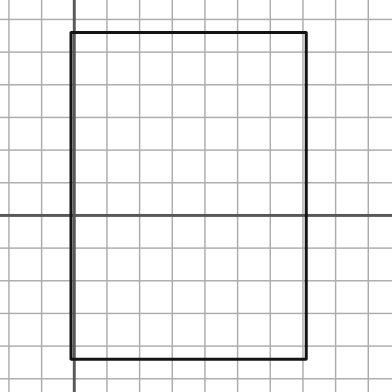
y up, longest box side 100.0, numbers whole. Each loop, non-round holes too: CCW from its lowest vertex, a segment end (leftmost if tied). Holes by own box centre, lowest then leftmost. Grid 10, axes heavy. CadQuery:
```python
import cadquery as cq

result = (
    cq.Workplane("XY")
    .moveTo(-1.0, -44.0)
    .lineTo(71.0, -44.0)
    .lineTo(71.0, 56.0)
    .lineTo(-1.0, 56.0)
    .close()
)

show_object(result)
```